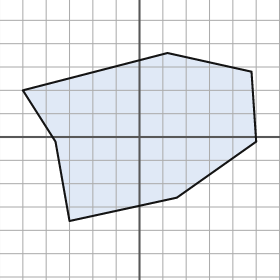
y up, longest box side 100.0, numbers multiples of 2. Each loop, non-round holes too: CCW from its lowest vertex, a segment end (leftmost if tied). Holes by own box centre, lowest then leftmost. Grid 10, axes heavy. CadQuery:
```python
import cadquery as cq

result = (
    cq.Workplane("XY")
    .moveTo(-30.0, -36.0)
    .lineTo(16.0, -26.0)
    .lineTo(50.0, -2.0)
    .lineTo(48.0, 28.0)
    .lineTo(12.0, 36.0)
    .lineTo(-50.0, 20.0)
    .lineTo(-36.0, -2.0)
    .close()
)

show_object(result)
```